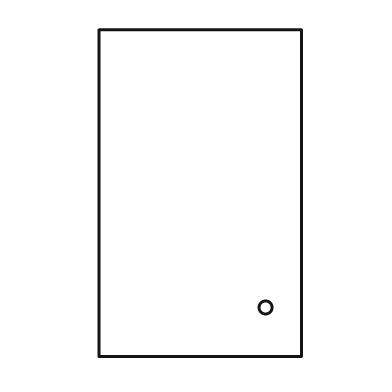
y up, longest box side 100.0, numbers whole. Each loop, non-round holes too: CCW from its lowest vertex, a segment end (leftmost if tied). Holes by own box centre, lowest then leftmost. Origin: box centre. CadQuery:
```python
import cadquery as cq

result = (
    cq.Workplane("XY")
    .moveTo(-31.0, -50.0)
    .lineTo(31.0, -50.0)
    .lineTo(31.0, 50.0)
    .lineTo(-31.0, 50.0)
    .close()
    .moveTo(20.0, -35.0)
    .circle(2.0)
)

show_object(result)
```